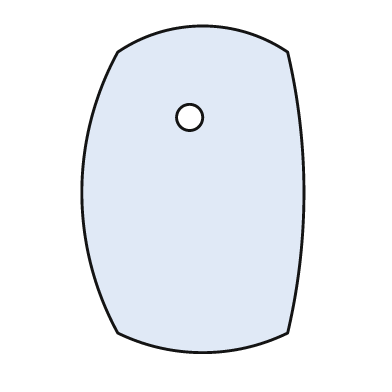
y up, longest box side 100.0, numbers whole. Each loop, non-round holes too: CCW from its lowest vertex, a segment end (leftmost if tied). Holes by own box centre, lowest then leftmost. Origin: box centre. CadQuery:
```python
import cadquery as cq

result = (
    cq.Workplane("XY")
    .moveTo(-23.0, -44.0)
    .threePointArc((3.0, -50.0), (29.0, -44.0))
    .threePointArc((34.0, -1.0), (29.0, 42.0))
    .threePointArc((3.0, 50.0), (-23.0, 42.0))
    .threePointArc((-34.0, -1.0), (-23.0, -44.0))
    .close()
    .moveTo(-1.0, 22.0)
    .circle(4.0)
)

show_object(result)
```